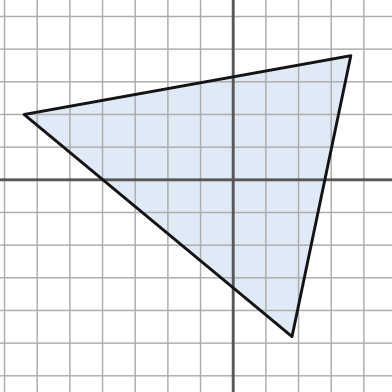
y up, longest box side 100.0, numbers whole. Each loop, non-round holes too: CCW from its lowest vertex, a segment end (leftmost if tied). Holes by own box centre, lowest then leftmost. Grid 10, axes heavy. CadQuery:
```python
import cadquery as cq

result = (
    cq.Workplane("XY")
    .moveTo(18.0, -48.0)
    .lineTo(36.0, 38.0)
    .lineTo(-64.0, 20.0)
    .close()
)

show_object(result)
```